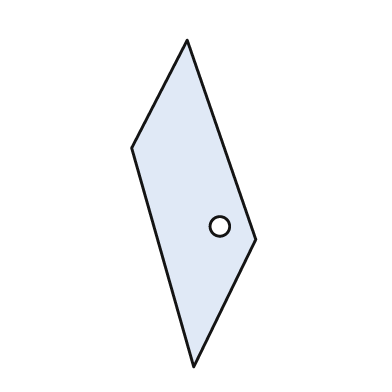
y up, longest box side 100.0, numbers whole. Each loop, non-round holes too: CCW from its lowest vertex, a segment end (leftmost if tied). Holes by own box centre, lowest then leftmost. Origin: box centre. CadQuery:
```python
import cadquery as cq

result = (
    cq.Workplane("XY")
    .moveTo(0.0, -50.0)
    .lineTo(19.0, -11.0)
    .lineTo(-2.0, 50.0)
    .lineTo(-19.0, 17.0)
    .close()
    .moveTo(8.0, -7.0)
    .circle(3.0)
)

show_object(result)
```